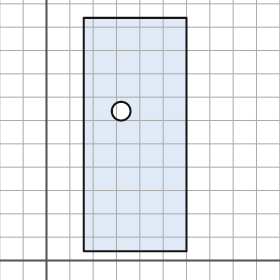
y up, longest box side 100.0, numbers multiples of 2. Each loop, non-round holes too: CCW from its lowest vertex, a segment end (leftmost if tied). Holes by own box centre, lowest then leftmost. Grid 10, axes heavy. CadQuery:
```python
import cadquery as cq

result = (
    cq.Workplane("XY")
    .moveTo(16.0, 4.0)
    .lineTo(60.0, 4.0)
    .lineTo(60.0, 104.0)
    .lineTo(16.0, 104.0)
    .close()
    .moveTo(32.0, 64.0)
    .circle(4.0)
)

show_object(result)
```